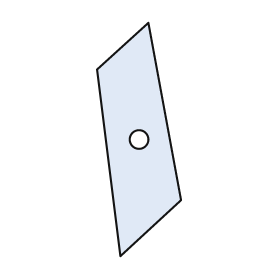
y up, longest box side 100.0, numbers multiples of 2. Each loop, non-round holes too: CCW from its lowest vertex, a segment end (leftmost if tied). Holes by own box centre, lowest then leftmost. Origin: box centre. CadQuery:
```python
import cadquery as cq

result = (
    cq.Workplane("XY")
    .moveTo(-8.0, -50.0)
    .lineTo(18.0, -26.0)
    .lineTo(4.0, 50.0)
    .lineTo(-18.0, 30.0)
    .close()
    .moveTo(0.0, 0.0)
    .circle(4.0)
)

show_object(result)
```